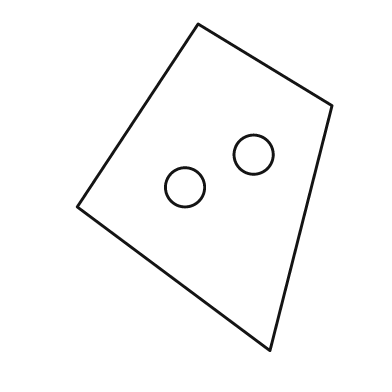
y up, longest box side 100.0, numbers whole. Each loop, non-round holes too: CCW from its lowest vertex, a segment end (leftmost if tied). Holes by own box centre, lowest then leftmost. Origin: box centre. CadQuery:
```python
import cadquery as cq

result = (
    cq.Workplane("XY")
    .moveTo(20.0, -50.0)
    .lineTo(39.0, 25.0)
    .lineTo(-2.0, 50.0)
    .lineTo(-39.0, -6.0)
    .close()
    .moveTo(-6.0, 0.0)
    .circle(6.0)
    .moveTo(15.0, 10.0)
    .circle(6.0)
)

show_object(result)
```